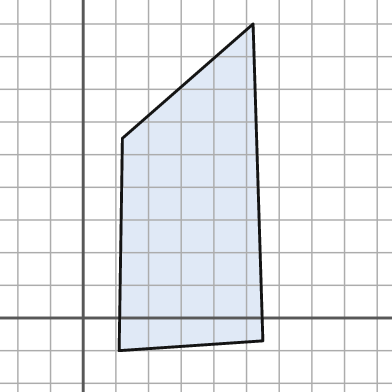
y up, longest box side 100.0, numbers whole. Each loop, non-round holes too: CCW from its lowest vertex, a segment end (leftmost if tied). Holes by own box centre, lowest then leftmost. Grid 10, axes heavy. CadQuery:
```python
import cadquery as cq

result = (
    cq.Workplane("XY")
    .moveTo(11.0, -10.0)
    .lineTo(55.0, -7.0)
    .lineTo(52.0, 90.0)
    .lineTo(12.0, 55.0)
    .close()
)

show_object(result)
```